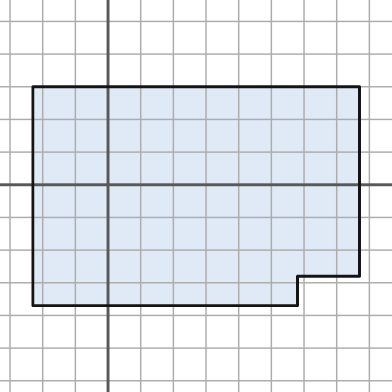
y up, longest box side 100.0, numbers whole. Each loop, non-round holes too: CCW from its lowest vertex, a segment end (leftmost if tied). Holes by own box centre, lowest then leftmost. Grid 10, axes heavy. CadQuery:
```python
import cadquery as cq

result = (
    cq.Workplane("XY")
    .moveTo(-23.0, -37.0)
    .lineTo(58.0, -37.0)
    .lineTo(58.0, -28.0)
    .lineTo(77.0, -28.0)
    .lineTo(77.0, 30.0)
    .lineTo(-23.0, 30.0)
    .close()
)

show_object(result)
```